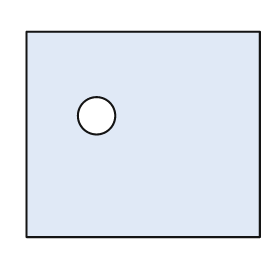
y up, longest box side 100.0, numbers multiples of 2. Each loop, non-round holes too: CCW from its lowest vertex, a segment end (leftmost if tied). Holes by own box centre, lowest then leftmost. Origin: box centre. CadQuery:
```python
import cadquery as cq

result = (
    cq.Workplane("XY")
    .moveTo(-50.0, -44.0)
    .lineTo(50.0, -44.0)
    .lineTo(50.0, 44.0)
    .lineTo(-50.0, 44.0)
    .close()
    .moveTo(-20.0, 8.0)
    .circle(8.0)
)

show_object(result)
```